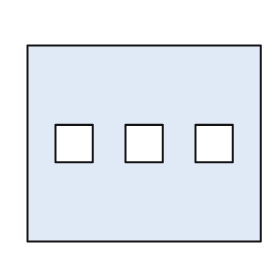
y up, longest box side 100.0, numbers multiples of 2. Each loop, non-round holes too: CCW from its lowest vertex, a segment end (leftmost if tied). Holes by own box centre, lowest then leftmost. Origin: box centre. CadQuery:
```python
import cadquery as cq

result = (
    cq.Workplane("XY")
    .moveTo(-50.0, -42.0)
    .lineTo(50.0, -42.0)
    .lineTo(50.0, 42.0)
    .lineTo(-50.0, 42.0)
    .close()
    .moveTo(-38.0, -8.0)
    .lineTo(-22.0, -8.0)
    .lineTo(-22.0, 8.0)
    .lineTo(-38.0, 8.0)
    .close()
    .moveTo(-8.0, -8.0)
    .lineTo(8.0, -8.0)
    .lineTo(8.0, 8.0)
    .lineTo(-8.0, 8.0)
    .close()
    .moveTo(22.0, -8.0)
    .lineTo(38.0, -8.0)
    .lineTo(38.0, 8.0)
    .lineTo(22.0, 8.0)
    .close()
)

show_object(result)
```